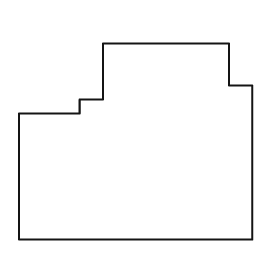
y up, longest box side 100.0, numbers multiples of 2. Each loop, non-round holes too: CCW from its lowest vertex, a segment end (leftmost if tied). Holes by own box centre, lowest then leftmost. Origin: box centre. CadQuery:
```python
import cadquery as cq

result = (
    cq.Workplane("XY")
    .moveTo(-50.0, -42.0)
    .lineTo(50.0, -42.0)
    .lineTo(50.0, 24.0)
    .lineTo(40.0, 24.0)
    .lineTo(40.0, 42.0)
    .lineTo(-14.0, 42.0)
    .lineTo(-14.0, 18.0)
    .lineTo(-24.0, 18.0)
    .lineTo(-24.0, 12.0)
    .lineTo(-50.0, 12.0)
    .close()
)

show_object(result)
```